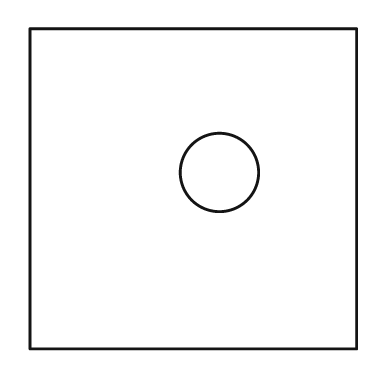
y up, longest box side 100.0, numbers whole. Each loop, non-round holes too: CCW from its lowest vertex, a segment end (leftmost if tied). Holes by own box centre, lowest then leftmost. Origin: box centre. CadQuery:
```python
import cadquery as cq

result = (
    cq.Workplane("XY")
    .moveTo(-50.0, -49.0)
    .lineTo(50.0, -49.0)
    .lineTo(50.0, 49.0)
    .lineTo(-50.0, 49.0)
    .close()
    .moveTo(8.0, 5.0)
    .circle(12.0)
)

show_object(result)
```